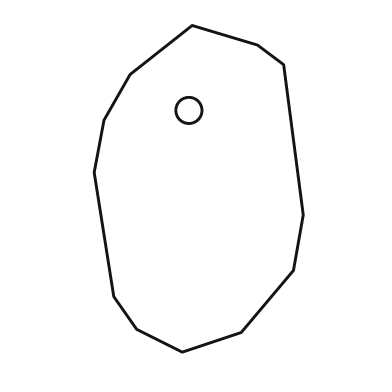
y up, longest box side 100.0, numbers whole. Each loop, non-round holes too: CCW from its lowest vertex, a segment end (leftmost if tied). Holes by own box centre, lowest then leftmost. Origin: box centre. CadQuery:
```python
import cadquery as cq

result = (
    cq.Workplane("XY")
    .moveTo(-5.0, -50.0)
    .lineTo(13.0, -44.0)
    .lineTo(29.0, -25.0)
    .lineTo(32.0, -8.0)
    .lineTo(26.0, 38.0)
    .lineTo(18.0, 44.0)
    .lineTo(-2.0, 50.0)
    .lineTo(-21.0, 35.0)
    .lineTo(-29.0, 21.0)
    .lineTo(-32.0, 5.0)
    .lineTo(-26.0, -33.0)
    .lineTo(-19.0, -43.0)
    .close()
    .moveTo(-3.0, 24.0)
    .circle(4.0)
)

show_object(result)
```